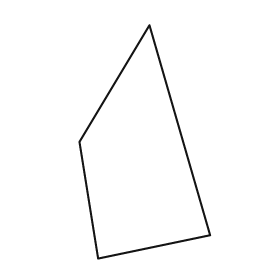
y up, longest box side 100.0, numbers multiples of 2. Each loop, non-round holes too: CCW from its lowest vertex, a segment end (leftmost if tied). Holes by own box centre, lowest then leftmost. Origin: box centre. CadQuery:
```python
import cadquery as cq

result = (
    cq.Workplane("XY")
    .moveTo(-20.0, -50.0)
    .lineTo(28.0, -40.0)
    .lineTo(2.0, 50.0)
    .lineTo(-28.0, 0.0)
    .close()
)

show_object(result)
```